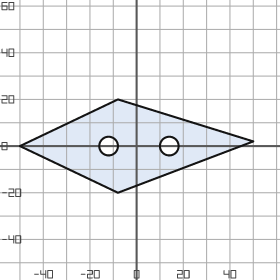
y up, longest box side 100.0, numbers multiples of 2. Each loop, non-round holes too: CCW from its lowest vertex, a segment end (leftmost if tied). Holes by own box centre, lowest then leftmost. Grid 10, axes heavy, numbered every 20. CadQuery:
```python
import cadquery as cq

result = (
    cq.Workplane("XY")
    .moveTo(-8.0, -20.0)
    .lineTo(50.0, 2.0)
    .lineTo(-8.0, 20.0)
    .lineTo(-50.0, 0.0)
    .close()
    .moveTo(-12.0, 0.0)
    .circle(4.0)
    .moveTo(14.0, 0.0)
    .circle(4.0)
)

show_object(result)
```